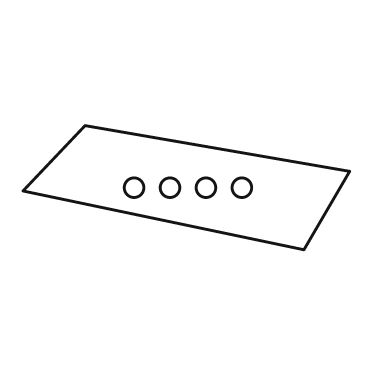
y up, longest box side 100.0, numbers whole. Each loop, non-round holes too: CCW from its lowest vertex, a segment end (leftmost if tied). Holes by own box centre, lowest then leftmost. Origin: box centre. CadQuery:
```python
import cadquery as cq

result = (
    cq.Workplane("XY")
    .moveTo(36.0, -19.0)
    .lineTo(50.0, 5.0)
    .lineTo(-31.0, 19.0)
    .lineTo(-50.0, -1.0)
    .close()
    .moveTo(-16.0, 0.0)
    .circle(3.0)
    .moveTo(-5.0, 0.0)
    .circle(3.0)
    .moveTo(6.0, 0.0)
    .circle(3.0)
    .moveTo(17.0, 0.0)
    .circle(3.0)
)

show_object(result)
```